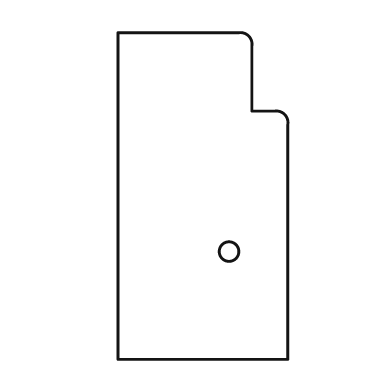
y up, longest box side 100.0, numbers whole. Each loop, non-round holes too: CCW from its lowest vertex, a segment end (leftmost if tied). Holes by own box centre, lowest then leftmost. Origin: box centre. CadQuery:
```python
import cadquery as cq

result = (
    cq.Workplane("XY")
    .moveTo(-26.0, -50.0)
    .lineTo(26.0, -50.0)
    .lineTo(26.0, 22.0)
    .threePointArc((25.0, 25.0), (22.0, 26.0))
    .lineTo(15.0, 26.0)
    .lineTo(15.0, 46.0)
    .threePointArc((14.0, 49.0), (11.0, 50.0))
    .lineTo(-26.0, 50.0)
    .close()
    .moveTo(8.0, -17.0)
    .circle(3.0)
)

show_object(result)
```